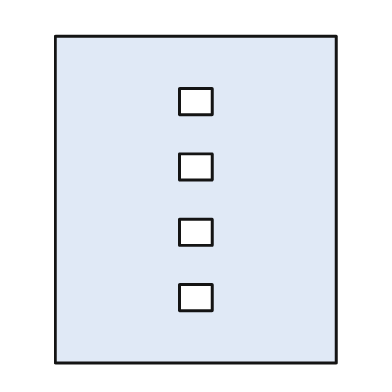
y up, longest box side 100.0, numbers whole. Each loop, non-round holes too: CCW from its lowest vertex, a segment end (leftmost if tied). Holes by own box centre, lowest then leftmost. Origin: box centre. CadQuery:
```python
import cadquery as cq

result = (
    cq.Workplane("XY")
    .moveTo(-43.0, -50.0)
    .lineTo(43.0, -50.0)
    .lineTo(43.0, 50.0)
    .lineTo(-43.0, 50.0)
    .close()
    .moveTo(-5.0, -34.0)
    .lineTo(5.0, -34.0)
    .lineTo(5.0, -26.0)
    .lineTo(-5.0, -26.0)
    .close()
    .moveTo(-5.0, -14.0)
    .lineTo(5.0, -14.0)
    .lineTo(5.0, -6.0)
    .lineTo(-5.0, -6.0)
    .close()
    .moveTo(-5.0, 6.0)
    .lineTo(5.0, 6.0)
    .lineTo(5.0, 14.0)
    .lineTo(-5.0, 14.0)
    .close()
    .moveTo(-5.0, 26.0)
    .lineTo(5.0, 26.0)
    .lineTo(5.0, 34.0)
    .lineTo(-5.0, 34.0)
    .close()
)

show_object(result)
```